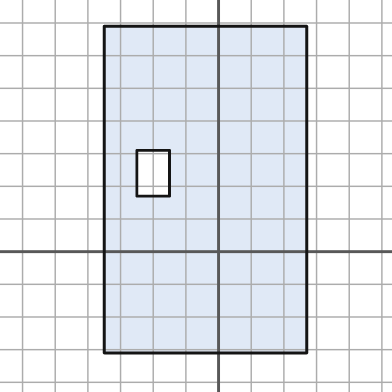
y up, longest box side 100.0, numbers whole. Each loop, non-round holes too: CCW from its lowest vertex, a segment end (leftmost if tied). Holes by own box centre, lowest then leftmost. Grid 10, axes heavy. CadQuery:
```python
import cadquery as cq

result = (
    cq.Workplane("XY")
    .moveTo(-35.0, -31.0)
    .lineTo(27.0, -31.0)
    .lineTo(27.0, 69.0)
    .lineTo(-35.0, 69.0)
    .close()
    .moveTo(-25.0, 17.0)
    .lineTo(-15.0, 17.0)
    .lineTo(-15.0, 31.0)
    .lineTo(-25.0, 31.0)
    .close()
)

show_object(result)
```